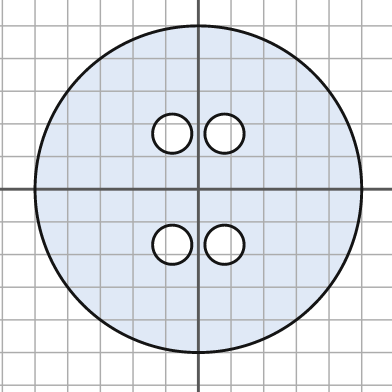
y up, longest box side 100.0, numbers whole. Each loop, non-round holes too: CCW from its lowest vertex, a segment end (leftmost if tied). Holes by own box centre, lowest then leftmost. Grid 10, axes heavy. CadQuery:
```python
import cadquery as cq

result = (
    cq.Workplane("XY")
    .moveTo(0.0, 0.0)
    .circle(50.0)
    .moveTo(-8.0, -17.0)
    .circle(6.0)
    .moveTo(8.0, -17.0)
    .circle(6.0)
    .moveTo(-8.0, 17.0)
    .circle(6.0)
    .moveTo(8.0, 17.0)
    .circle(6.0)
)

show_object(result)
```